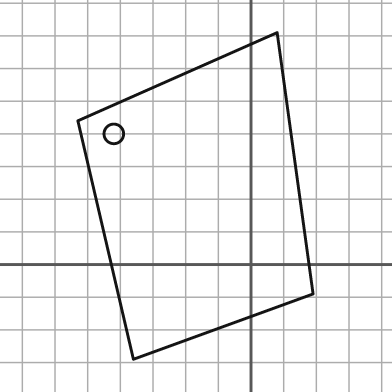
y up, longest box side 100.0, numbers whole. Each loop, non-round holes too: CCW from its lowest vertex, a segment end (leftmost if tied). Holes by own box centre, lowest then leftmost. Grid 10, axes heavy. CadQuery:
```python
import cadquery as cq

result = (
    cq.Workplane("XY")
    .moveTo(-36.0, -29.0)
    .lineTo(19.0, -9.0)
    .lineTo(8.0, 71.0)
    .lineTo(-53.0, 44.0)
    .close()
    .moveTo(-42.0, 40.0)
    .circle(3.0)
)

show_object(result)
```